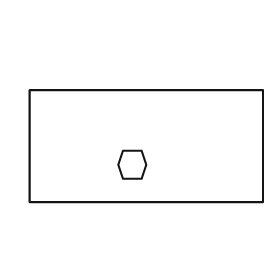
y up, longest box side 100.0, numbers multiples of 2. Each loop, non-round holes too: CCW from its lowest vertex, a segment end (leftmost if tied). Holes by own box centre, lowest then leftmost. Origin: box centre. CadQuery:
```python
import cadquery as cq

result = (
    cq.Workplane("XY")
    .moveTo(-50.0, -24.0)
    .lineTo(50.0, -24.0)
    .lineTo(50.0, 24.0)
    .lineTo(-50.0, 24.0)
    .close()
    .moveTo(-10.0, -14.0)
    .lineTo(-2.0, -14.0)
    .lineTo(0.0, -8.0)
    .lineTo(-2.0, -2.0)
    .lineTo(-10.0, -2.0)
    .lineTo(-12.0, -8.0)
    .close()
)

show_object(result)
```